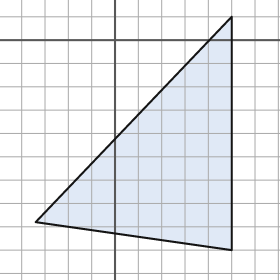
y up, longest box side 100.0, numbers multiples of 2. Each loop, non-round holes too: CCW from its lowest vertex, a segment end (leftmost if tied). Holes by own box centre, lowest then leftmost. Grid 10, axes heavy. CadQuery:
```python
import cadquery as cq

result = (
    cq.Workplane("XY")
    .moveTo(50.0, -90.0)
    .lineTo(50.0, 10.0)
    .lineTo(-34.0, -78.0)
    .close()
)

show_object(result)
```